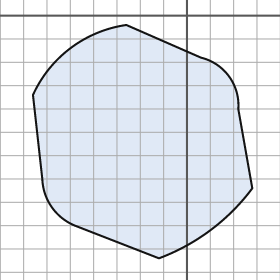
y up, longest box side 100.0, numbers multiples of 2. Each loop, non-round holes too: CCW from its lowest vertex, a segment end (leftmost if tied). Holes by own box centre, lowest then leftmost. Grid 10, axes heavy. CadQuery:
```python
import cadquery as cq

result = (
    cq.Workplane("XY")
    .moveTo(-12.0, -104.0)
    .threePointArc((10.0, -92.0), (28.0, -74.0))
    .lineTo(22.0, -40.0)
    .threePointArc((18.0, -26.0), (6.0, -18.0))
    .lineTo(-26.0, -4.0)
    .threePointArc((-50.0, -14.0), (-66.0, -34.0))
    .lineTo(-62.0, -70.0)
    .threePointArc((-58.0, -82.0), (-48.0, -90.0))
    .close()
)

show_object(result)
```